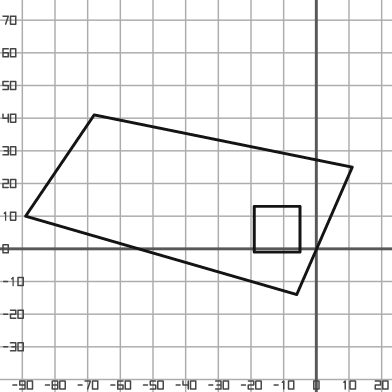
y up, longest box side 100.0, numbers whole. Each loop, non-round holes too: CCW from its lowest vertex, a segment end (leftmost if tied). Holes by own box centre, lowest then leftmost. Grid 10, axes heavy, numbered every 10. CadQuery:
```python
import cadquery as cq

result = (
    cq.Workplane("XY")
    .moveTo(-6.0, -14.0)
    .lineTo(11.0, 25.0)
    .lineTo(-68.0, 41.0)
    .lineTo(-89.0, 10.0)
    .close()
    .moveTo(-19.0, -1.0)
    .lineTo(-5.0, -1.0)
    .lineTo(-5.0, 13.0)
    .lineTo(-19.0, 13.0)
    .close()
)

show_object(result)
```